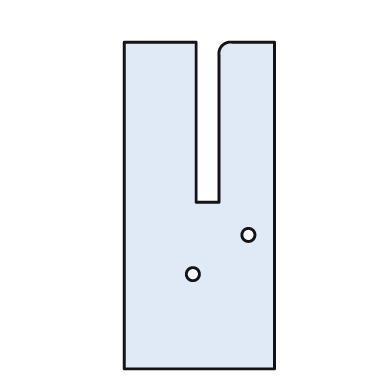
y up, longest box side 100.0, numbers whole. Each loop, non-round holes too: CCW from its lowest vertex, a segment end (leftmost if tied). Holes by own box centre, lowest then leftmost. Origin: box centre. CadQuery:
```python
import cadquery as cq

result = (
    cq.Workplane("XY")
    .moveTo(-23.0, -50.0)
    .lineTo(23.0, -50.0)
    .lineTo(23.0, 50.0)
    .lineTo(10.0, 50.0)
    .threePointArc((7.0, 49.0), (6.0, 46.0))
    .lineTo(6.0, 1.0)
    .lineTo(-1.0, 1.0)
    .lineTo(-1.0, 50.0)
    .lineTo(-23.0, 50.0)
    .close()
    .moveTo(-2.0, -21.0)
    .circle(2.0)
    .moveTo(15.0, -9.0)
    .circle(2.0)
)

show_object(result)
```